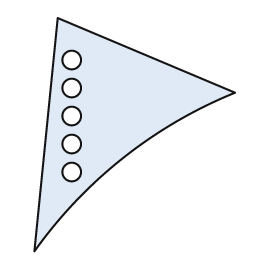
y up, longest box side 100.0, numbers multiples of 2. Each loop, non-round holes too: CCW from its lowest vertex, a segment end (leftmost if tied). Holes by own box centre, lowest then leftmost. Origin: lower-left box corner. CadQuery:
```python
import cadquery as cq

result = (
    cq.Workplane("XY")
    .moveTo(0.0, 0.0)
    .threePointArc((38.0, 40.0), (86.0, 68.0))
    .lineTo(10.0, 100.0)
    .close()
    .moveTo(16.0, 34.0)
    .circle(4.0)
    .moveTo(16.0, 46.0)
    .circle(4.0)
    .moveTo(16.0, 58.0)
    .circle(4.0)
    .moveTo(16.0, 70.0)
    .circle(4.0)
    .moveTo(16.0, 82.0)
    .circle(4.0)
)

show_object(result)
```